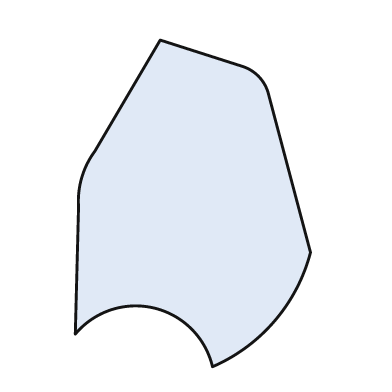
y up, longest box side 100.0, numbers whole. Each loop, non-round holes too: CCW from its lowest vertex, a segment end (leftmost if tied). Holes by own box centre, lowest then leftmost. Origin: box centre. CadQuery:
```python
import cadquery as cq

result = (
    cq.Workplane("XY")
    .moveTo(6.0, -50.0)
    .threePointArc((25.0, -36.0), (36.0, -15.0))
    .lineTo(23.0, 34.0)
    .threePointArc((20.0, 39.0), (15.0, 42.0))
    .lineTo(-10.0, 50.0)
    .lineTo(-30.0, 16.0)
    .threePointArc((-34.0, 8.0), (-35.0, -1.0))
    .lineTo(-36.0, -40.0)
    .threePointArc((-12.0, -32.0), (6.0, -50.0))
    .close()
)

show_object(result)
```